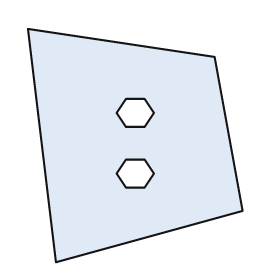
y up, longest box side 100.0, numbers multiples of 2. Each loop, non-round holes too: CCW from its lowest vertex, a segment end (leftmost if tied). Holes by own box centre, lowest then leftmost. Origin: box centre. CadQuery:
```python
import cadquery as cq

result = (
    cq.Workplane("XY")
    .moveTo(-34.0, -50.0)
    .lineTo(46.0, -28.0)
    .lineTo(34.0, 38.0)
    .lineTo(-46.0, 50.0)
    .close()
    .moveTo(-4.0, -18.0)
    .lineTo(4.0, -18.0)
    .lineTo(8.0, -12.0)
    .lineTo(4.0, -6.0)
    .lineTo(-4.0, -6.0)
    .lineTo(-8.0, -12.0)
    .close()
    .moveTo(-4.0, 8.0)
    .lineTo(4.0, 8.0)
    .lineTo(8.0, 14.0)
    .lineTo(4.0, 20.0)
    .lineTo(-4.0, 20.0)
    .lineTo(-8.0, 14.0)
    .close()
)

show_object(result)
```